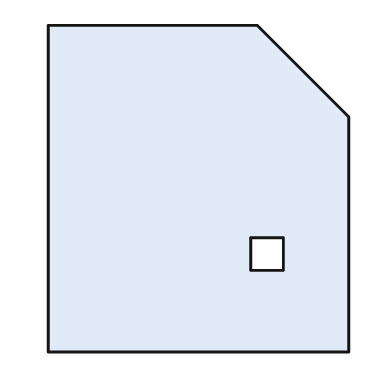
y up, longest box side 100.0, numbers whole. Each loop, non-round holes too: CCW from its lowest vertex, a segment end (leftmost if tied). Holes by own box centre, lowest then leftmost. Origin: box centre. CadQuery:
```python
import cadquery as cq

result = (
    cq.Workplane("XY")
    .moveTo(-46.0, -50.0)
    .lineTo(46.0, -50.0)
    .lineTo(46.0, 22.0)
    .lineTo(18.0, 50.0)
    .lineTo(-46.0, 50.0)
    .close()
    .moveTo(16.0, -25.0)
    .lineTo(26.0, -25.0)
    .lineTo(26.0, -15.0)
    .lineTo(16.0, -15.0)
    .close()
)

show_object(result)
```